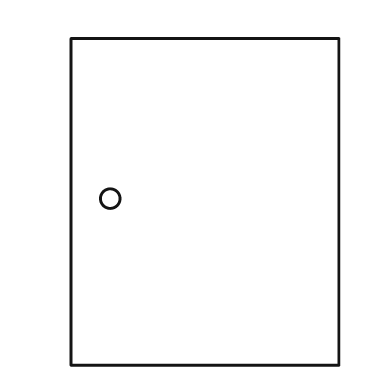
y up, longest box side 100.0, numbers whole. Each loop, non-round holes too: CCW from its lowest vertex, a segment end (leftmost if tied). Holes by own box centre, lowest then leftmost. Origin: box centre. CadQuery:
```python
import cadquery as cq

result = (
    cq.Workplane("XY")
    .moveTo(-41.0, -50.0)
    .lineTo(41.0, -50.0)
    .lineTo(41.0, 50.0)
    .lineTo(-41.0, 50.0)
    .close()
    .moveTo(-29.0, 1.0)
    .circle(3.0)
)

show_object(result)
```